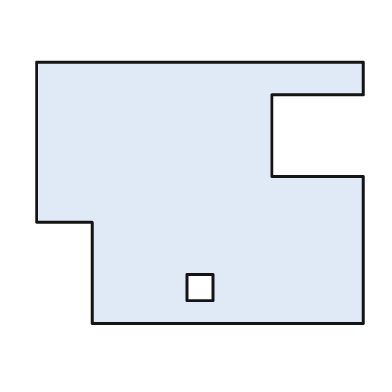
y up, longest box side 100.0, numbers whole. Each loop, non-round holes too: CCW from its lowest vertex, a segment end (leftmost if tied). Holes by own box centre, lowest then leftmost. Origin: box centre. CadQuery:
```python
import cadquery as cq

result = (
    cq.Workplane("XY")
    .moveTo(-33.0, -40.0)
    .lineTo(50.0, -40.0)
    .lineTo(50.0, 5.0)
    .lineTo(22.0, 5.0)
    .lineTo(22.0, 30.0)
    .lineTo(50.0, 30.0)
    .lineTo(50.0, 40.0)
    .lineTo(-50.0, 40.0)
    .lineTo(-50.0, -9.0)
    .lineTo(-33.0, -9.0)
    .close()
    .moveTo(-4.0, -33.0)
    .lineTo(4.0, -33.0)
    .lineTo(4.0, -25.0)
    .lineTo(-4.0, -25.0)
    .close()
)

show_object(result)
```